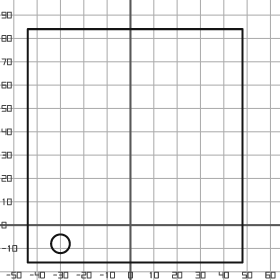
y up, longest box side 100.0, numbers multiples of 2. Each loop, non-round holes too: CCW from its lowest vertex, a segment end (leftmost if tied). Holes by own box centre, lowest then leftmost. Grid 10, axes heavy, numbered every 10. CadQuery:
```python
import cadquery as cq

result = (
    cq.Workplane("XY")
    .moveTo(-44.0, -16.0)
    .lineTo(48.0, -16.0)
    .lineTo(48.0, 84.0)
    .lineTo(-44.0, 84.0)
    .close()
    .moveTo(-30.0, -8.0)
    .circle(4.0)
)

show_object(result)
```